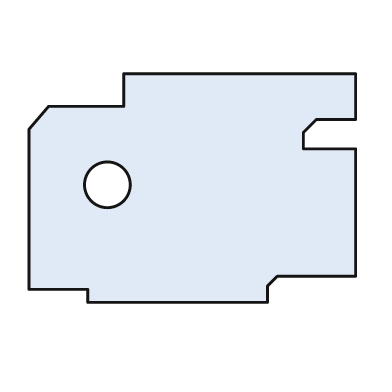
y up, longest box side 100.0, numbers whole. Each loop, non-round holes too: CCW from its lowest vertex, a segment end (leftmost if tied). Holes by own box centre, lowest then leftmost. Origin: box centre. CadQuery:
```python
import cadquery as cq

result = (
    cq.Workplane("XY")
    .moveTo(-32.0, -35.0)
    .lineTo(23.0, -35.0)
    .lineTo(23.0, -30.0)
    .lineTo(26.0, -27.0)
    .lineTo(50.0, -27.0)
    .lineTo(50.0, 12.0)
    .lineTo(34.0, 12.0)
    .lineTo(34.0, 17.0)
    .lineTo(38.0, 21.0)
    .lineTo(50.0, 21.0)
    .lineTo(50.0, 35.0)
    .lineTo(-21.0, 35.0)
    .lineTo(-21.0, 25.0)
    .lineTo(-44.0, 25.0)
    .lineTo(-50.0, 18.0)
    .lineTo(-50.0, -31.0)
    .lineTo(-32.0, -31.0)
    .close()
    .moveTo(-26.0, 1.0)
    .circle(7.0)
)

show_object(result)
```